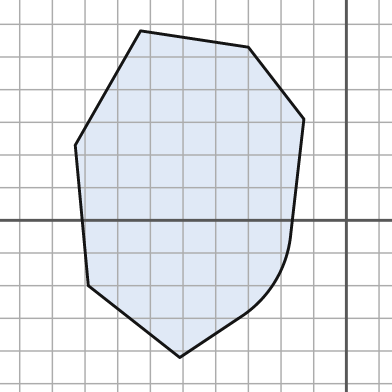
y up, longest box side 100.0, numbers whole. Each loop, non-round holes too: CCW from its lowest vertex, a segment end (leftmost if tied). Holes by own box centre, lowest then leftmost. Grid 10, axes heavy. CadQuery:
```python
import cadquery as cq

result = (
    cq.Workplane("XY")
    .moveTo(-51.0, -42.0)
    .lineTo(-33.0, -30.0)
    .threePointArc((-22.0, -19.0), (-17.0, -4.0))
    .lineTo(-13.0, 31.0)
    .lineTo(-30.0, 53.0)
    .lineTo(-63.0, 58.0)
    .lineTo(-83.0, 23.0)
    .lineTo(-79.0, -20.0)
    .close()
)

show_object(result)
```